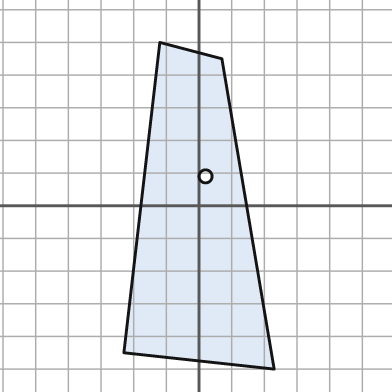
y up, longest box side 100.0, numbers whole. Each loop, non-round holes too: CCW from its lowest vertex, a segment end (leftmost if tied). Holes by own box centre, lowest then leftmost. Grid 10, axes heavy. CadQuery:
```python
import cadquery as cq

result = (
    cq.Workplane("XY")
    .moveTo(23.0, -50.0)
    .lineTo(7.0, 45.0)
    .lineTo(-12.0, 50.0)
    .lineTo(-23.0, -45.0)
    .close()
    .moveTo(2.0, 9.0)
    .circle(2.0)
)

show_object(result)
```